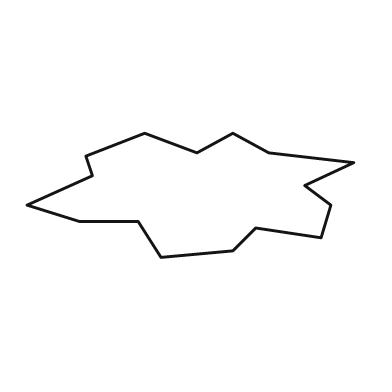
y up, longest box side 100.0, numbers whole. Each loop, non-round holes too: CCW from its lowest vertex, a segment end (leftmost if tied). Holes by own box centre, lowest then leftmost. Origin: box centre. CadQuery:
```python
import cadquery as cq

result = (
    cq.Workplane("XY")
    .moveTo(-9.0, -19.0)
    .lineTo(13.0, -17.0)
    .lineTo(20.0, -10.0)
    .lineTo(40.0, -13.0)
    .lineTo(43.0, -3.0)
    .lineTo(35.0, 3.0)
    .lineTo(50.0, 10.0)
    .lineTo(24.0, 13.0)
    .lineTo(13.0, 19.0)
    .lineTo(2.0, 13.0)
    .lineTo(-14.0, 19.0)
    .lineTo(-32.0, 12.0)
    .lineTo(-30.0, 6.0)
    .lineTo(-50.0, -3.0)
    .lineTo(-34.0, -8.0)
    .lineTo(-16.0, -8.0)
    .close()
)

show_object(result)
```